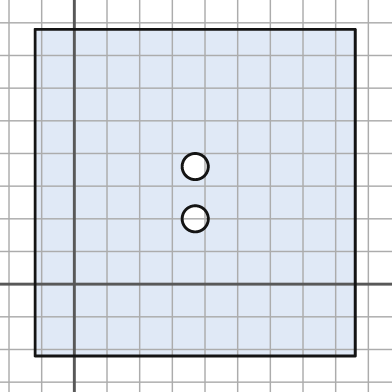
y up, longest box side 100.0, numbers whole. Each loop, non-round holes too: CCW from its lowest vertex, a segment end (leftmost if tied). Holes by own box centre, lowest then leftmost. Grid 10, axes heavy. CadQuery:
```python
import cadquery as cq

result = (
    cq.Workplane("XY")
    .moveTo(-12.0, -22.0)
    .lineTo(86.0, -22.0)
    .lineTo(86.0, 78.0)
    .lineTo(-12.0, 78.0)
    .close()
    .moveTo(37.0, 20.0)
    .circle(4.0)
    .moveTo(37.0, 36.0)
    .circle(4.0)
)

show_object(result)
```